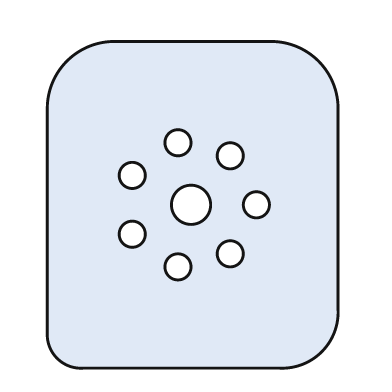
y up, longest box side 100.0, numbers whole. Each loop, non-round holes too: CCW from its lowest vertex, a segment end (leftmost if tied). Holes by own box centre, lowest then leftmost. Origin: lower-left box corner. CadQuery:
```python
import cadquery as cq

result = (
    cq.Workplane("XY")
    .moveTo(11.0, 0.0)
    .lineTo(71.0, 0.0)
    .threePointArc((84.0, 5.0), (89.0, 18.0))
    .lineTo(89.0, 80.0)
    .threePointArc((83.0, 94.0), (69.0, 100.0))
    .lineTo(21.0, 100.0)
    .threePointArc((6.0, 94.0), (0.0, 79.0))
    .lineTo(0.0, 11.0)
    .threePointArc((3.0, 3.0), (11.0, 0.0))
    .close()
    .moveTo(40.0, 31.0)
    .circle(4.0)
    .moveTo(56.0, 35.0)
    .circle(4.0)
    .moveTo(26.0, 41.0)
    .circle(4.0)
    .moveTo(44.0, 50.0)
    .circle(6.0)
    .moveTo(64.0, 50.0)
    .circle(4.0)
    .moveTo(26.0, 59.0)
    .circle(4.0)
    .moveTo(56.0, 65.0)
    .circle(4.0)
    .moveTo(40.0, 69.0)
    .circle(4.0)
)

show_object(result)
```